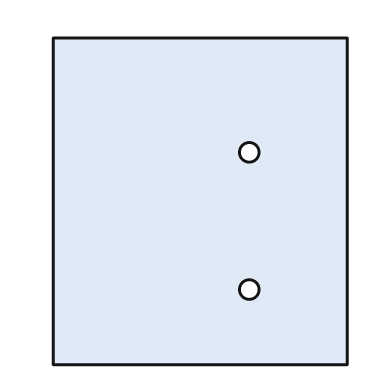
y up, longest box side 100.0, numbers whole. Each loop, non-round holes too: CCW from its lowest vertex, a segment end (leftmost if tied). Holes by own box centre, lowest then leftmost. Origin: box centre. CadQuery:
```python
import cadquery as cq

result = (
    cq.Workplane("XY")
    .moveTo(-45.0, -50.0)
    .lineTo(45.0, -50.0)
    .lineTo(45.0, 50.0)
    .lineTo(-45.0, 50.0)
    .close()
    .moveTo(15.0, -27.0)
    .circle(3.0)
    .moveTo(15.0, 15.0)
    .circle(3.0)
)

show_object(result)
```